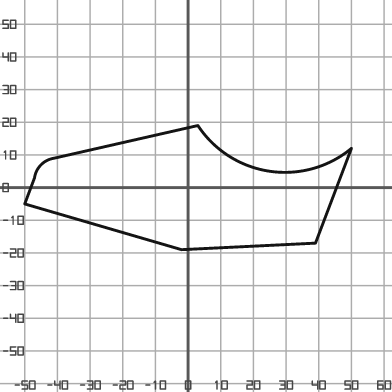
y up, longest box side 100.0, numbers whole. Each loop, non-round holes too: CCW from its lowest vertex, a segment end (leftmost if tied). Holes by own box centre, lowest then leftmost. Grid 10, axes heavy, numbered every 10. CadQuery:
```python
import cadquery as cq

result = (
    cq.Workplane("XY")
    .moveTo(-2.0, -19.0)
    .lineTo(39.0, -17.0)
    .lineTo(50.0, 12.0)
    .threePointArc((25.0, 5.0), (3.0, 19.0))
    .lineTo(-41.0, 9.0)
    .threePointArc((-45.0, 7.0), (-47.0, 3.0))
    .lineTo(-50.0, -5.0)
    .close()
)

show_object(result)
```